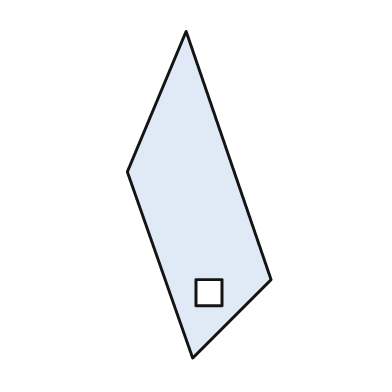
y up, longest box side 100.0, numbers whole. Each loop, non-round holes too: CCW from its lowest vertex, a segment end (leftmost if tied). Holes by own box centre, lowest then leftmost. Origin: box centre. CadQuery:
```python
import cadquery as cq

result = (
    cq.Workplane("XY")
    .moveTo(-2.0, -50.0)
    .lineTo(22.0, -26.0)
    .lineTo(-4.0, 50.0)
    .lineTo(-22.0, 7.0)
    .close()
    .moveTo(-1.0, -34.0)
    .lineTo(7.0, -34.0)
    .lineTo(7.0, -26.0)
    .lineTo(-1.0, -26.0)
    .close()
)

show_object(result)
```